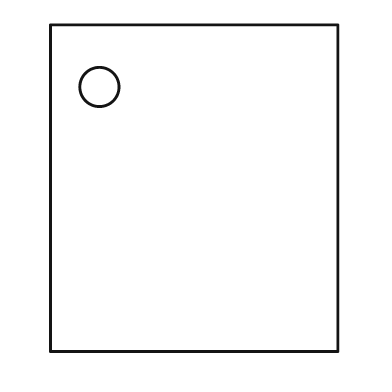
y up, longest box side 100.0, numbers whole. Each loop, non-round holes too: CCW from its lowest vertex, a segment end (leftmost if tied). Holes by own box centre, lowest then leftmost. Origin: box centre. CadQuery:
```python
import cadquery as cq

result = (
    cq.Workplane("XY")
    .moveTo(-44.0, -50.0)
    .lineTo(44.0, -50.0)
    .lineTo(44.0, 50.0)
    .lineTo(-44.0, 50.0)
    .close()
    .moveTo(-29.0, 31.0)
    .circle(6.0)
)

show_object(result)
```